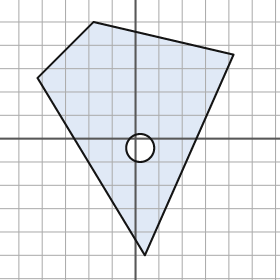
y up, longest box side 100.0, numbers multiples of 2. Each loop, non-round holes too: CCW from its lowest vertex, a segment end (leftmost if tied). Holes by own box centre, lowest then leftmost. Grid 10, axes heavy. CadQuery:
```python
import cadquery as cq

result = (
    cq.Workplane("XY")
    .moveTo(4.0, -50.0)
    .lineTo(42.0, 36.0)
    .lineTo(-18.0, 50.0)
    .lineTo(-42.0, 26.0)
    .close()
    .moveTo(2.0, -4.0)
    .circle(6.0)
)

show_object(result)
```